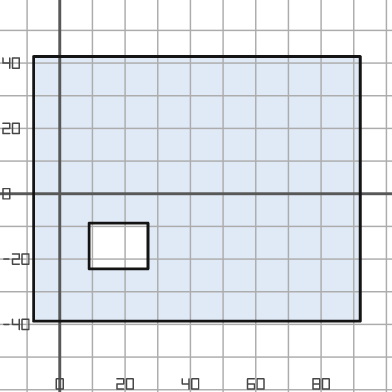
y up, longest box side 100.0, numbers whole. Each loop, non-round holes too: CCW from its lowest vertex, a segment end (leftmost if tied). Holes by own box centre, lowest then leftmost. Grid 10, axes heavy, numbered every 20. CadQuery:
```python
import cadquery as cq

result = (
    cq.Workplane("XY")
    .moveTo(-8.0, -39.0)
    .lineTo(92.0, -39.0)
    .lineTo(92.0, 42.0)
    .lineTo(-8.0, 42.0)
    .close()
    .moveTo(9.0, -23.0)
    .lineTo(27.0, -23.0)
    .lineTo(27.0, -9.0)
    .lineTo(9.0, -9.0)
    .close()
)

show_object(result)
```